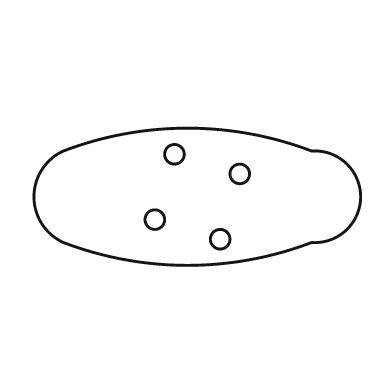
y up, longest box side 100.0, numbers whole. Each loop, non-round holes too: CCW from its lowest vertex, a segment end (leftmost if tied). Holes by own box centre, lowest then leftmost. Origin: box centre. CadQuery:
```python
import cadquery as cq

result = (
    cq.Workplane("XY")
    .moveTo(-41.0, -14.0)
    .threePointArc((-3.0, -21.0), (35.0, -14.0))
    .threePointArc((50.0, 0.0), (35.0, 14.0))
    .threePointArc((-3.0, 21.0), (-41.0, 14.0))
    .threePointArc((-50.0, 0.0), (-41.0, -14.0))
    .close()
    .moveTo(7.0, -13.0)
    .circle(3.0)
    .moveTo(-13.0, -7.0)
    .circle(3.0)
    .moveTo(13.0, 7.0)
    .circle(3.0)
    .moveTo(-7.0, 13.0)
    .circle(3.0)
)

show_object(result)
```